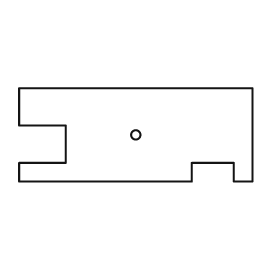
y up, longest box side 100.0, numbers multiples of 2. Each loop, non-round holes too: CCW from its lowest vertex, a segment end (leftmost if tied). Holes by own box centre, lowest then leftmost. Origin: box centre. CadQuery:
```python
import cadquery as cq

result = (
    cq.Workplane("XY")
    .moveTo(-50.0, -20.0)
    .lineTo(24.0, -20.0)
    .lineTo(24.0, -12.0)
    .lineTo(42.0, -12.0)
    .lineTo(42.0, -20.0)
    .lineTo(50.0, -20.0)
    .lineTo(50.0, 20.0)
    .lineTo(-50.0, 20.0)
    .lineTo(-50.0, 4.0)
    .lineTo(-30.0, 4.0)
    .lineTo(-30.0, -12.0)
    .lineTo(-50.0, -12.0)
    .close()
    .moveTo(0.0, 0.0)
    .circle(2.0)
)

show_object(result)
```